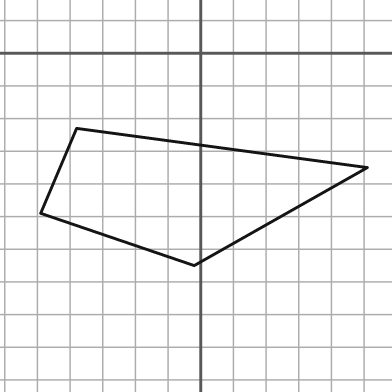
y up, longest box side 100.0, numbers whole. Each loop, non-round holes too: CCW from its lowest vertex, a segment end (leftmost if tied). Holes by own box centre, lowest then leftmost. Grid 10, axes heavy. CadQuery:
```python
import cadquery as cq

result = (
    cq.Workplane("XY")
    .moveTo(-2.0, -65.0)
    .lineTo(51.0, -35.0)
    .lineTo(-38.0, -23.0)
    .lineTo(-49.0, -49.0)
    .close()
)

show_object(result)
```